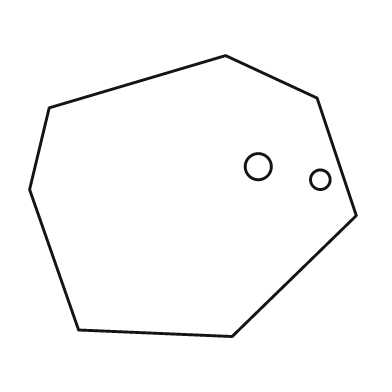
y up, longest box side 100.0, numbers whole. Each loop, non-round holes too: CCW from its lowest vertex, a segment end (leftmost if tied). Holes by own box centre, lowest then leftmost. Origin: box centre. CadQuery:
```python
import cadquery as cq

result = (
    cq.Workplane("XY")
    .moveTo(12.0, -43.0)
    .lineTo(50.0, -6.0)
    .lineTo(38.0, 30.0)
    .lineTo(10.0, 43.0)
    .lineTo(-44.0, 27.0)
    .lineTo(-50.0, 2.0)
    .lineTo(-35.0, -41.0)
    .close()
    .moveTo(39.0, 5.0)
    .circle(3.0)
    .moveTo(20.0, 9.0)
    .circle(4.0)
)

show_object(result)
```